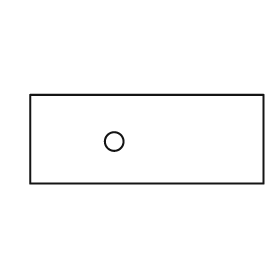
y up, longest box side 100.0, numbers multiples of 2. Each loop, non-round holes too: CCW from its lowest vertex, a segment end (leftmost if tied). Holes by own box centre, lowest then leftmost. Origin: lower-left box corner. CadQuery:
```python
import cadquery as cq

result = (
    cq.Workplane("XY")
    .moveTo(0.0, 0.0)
    .lineTo(100.0, 0.0)
    .lineTo(100.0, 38.0)
    .lineTo(0.0, 38.0)
    .close()
    .moveTo(36.0, 18.0)
    .circle(4.0)
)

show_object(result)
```